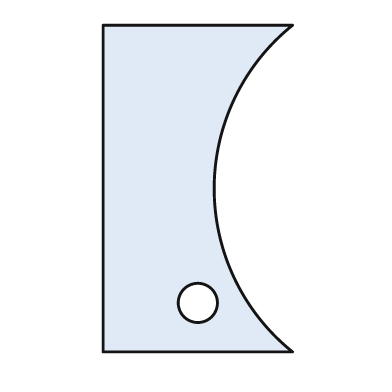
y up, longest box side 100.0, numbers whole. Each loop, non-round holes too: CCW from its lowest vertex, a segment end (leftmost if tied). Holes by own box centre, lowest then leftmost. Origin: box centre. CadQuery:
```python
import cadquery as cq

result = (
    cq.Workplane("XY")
    .moveTo(-29.0, -50.0)
    .lineTo(29.0, -50.0)
    .threePointArc((5.0, 0.0), (29.0, 50.0))
    .lineTo(-29.0, 50.0)
    .close()
    .moveTo(0.0, -35.0)
    .circle(6.0)
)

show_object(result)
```